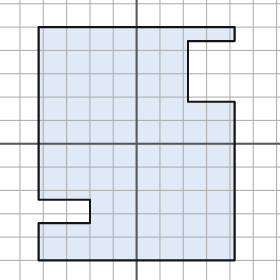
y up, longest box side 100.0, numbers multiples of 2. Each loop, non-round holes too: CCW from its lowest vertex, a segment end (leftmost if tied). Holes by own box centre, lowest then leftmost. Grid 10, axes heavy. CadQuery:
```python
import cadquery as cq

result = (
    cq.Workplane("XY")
    .moveTo(-42.0, -50.0)
    .lineTo(42.0, -50.0)
    .lineTo(42.0, 18.0)
    .lineTo(22.0, 18.0)
    .lineTo(22.0, 44.0)
    .lineTo(42.0, 44.0)
    .lineTo(42.0, 50.0)
    .lineTo(-42.0, 50.0)
    .lineTo(-42.0, -24.0)
    .lineTo(-20.0, -24.0)
    .lineTo(-20.0, -34.0)
    .lineTo(-42.0, -34.0)
    .close()
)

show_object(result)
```